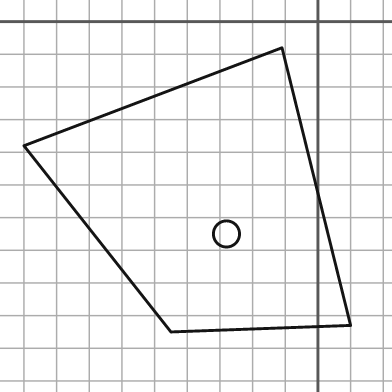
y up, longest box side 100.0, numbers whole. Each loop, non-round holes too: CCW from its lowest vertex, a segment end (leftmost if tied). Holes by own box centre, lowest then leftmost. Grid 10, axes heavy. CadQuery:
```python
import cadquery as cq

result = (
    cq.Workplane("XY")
    .moveTo(-45.0, -95.0)
    .lineTo(10.0, -93.0)
    .lineTo(-11.0, -8.0)
    .lineTo(-90.0, -38.0)
    .close()
    .moveTo(-28.0, -65.0)
    .circle(4.0)
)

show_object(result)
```